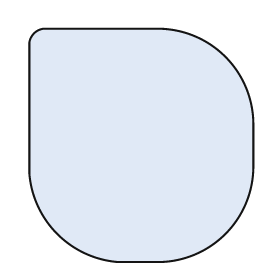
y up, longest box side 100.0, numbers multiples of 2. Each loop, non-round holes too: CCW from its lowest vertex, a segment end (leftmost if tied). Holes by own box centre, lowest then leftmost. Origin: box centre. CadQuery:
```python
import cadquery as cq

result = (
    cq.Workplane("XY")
    .moveTo(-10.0, -50.0)
    .lineTo(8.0, -50.0)
    .threePointArc((36.0, -38.0), (48.0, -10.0))
    .lineTo(48.0, 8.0)
    .threePointArc((36.0, 38.0), (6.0, 50.0))
    .lineTo(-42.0, 50.0)
    .threePointArc((-46.0, 48.0), (-48.0, 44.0))
    .lineTo(-48.0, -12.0)
    .threePointArc((-36.0, -38.0), (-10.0, -50.0))
    .close()
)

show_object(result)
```